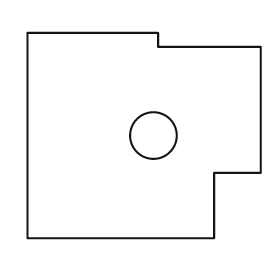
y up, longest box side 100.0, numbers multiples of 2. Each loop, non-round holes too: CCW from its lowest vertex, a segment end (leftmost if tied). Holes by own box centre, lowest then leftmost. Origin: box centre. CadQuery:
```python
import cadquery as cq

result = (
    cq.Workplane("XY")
    .moveTo(-50.0, -44.0)
    .lineTo(30.0, -44.0)
    .lineTo(30.0, -16.0)
    .lineTo(50.0, -16.0)
    .lineTo(50.0, 38.0)
    .lineTo(6.0, 38.0)
    .lineTo(6.0, 44.0)
    .lineTo(-50.0, 44.0)
    .close()
    .moveTo(4.0, 0.0)
    .circle(10.0)
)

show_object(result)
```